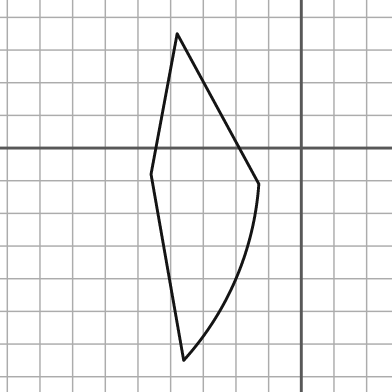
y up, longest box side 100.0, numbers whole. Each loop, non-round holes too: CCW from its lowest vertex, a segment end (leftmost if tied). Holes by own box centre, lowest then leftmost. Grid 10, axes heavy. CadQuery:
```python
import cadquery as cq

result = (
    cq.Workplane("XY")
    .moveTo(-36.0, -65.0)
    .threePointArc((-20.0, -40.0), (-13.0, -11.0))
    .lineTo(-38.0, 35.0)
    .lineTo(-46.0, -8.0)
    .close()
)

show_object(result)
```